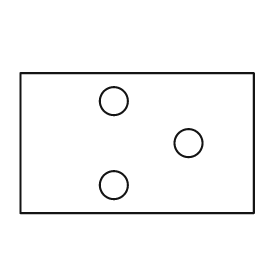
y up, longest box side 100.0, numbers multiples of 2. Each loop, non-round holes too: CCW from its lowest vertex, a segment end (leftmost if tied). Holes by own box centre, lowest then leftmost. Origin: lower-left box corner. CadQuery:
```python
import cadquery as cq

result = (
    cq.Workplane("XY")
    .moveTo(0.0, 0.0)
    .lineTo(100.0, 0.0)
    .lineTo(100.0, 60.0)
    .lineTo(0.0, 60.0)
    .close()
    .moveTo(40.0, 12.0)
    .circle(6.0)
    .moveTo(72.0, 30.0)
    .circle(6.0)
    .moveTo(40.0, 48.0)
    .circle(6.0)
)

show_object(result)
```